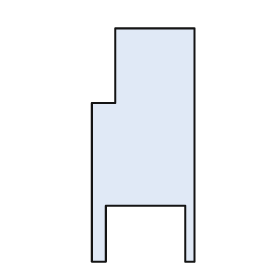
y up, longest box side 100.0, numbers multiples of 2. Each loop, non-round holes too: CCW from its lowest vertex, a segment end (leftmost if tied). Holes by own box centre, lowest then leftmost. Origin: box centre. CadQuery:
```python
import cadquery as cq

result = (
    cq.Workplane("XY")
    .moveTo(-22.0, -50.0)
    .lineTo(-16.0, -50.0)
    .lineTo(-16.0, -26.0)
    .lineTo(18.0, -26.0)
    .lineTo(18.0, -50.0)
    .lineTo(22.0, -50.0)
    .lineTo(22.0, 50.0)
    .lineTo(-12.0, 50.0)
    .lineTo(-12.0, 18.0)
    .lineTo(-22.0, 18.0)
    .close()
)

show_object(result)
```